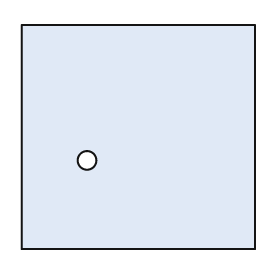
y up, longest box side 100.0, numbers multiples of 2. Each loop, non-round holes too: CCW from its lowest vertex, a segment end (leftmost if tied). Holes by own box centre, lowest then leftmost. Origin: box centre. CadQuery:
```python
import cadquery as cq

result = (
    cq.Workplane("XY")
    .moveTo(-50.0, -48.0)
    .lineTo(50.0, -48.0)
    .lineTo(50.0, 48.0)
    .lineTo(-50.0, 48.0)
    .close()
    .moveTo(-22.0, -10.0)
    .circle(4.0)
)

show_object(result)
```